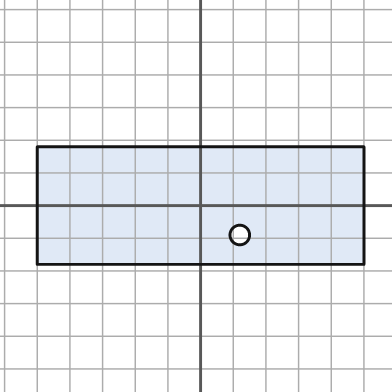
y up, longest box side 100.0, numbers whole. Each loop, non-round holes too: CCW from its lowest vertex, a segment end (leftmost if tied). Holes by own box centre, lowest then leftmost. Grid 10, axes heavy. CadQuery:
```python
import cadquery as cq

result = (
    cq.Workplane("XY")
    .moveTo(-50.0, -18.0)
    .lineTo(50.0, -18.0)
    .lineTo(50.0, 18.0)
    .lineTo(-50.0, 18.0)
    .close()
    .moveTo(12.0, -9.0)
    .circle(3.0)
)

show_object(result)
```